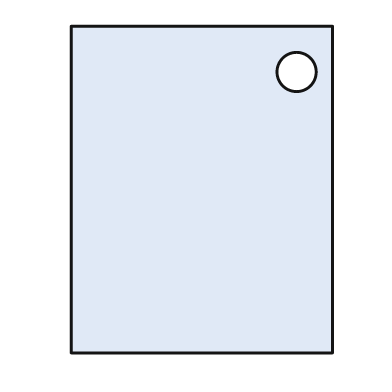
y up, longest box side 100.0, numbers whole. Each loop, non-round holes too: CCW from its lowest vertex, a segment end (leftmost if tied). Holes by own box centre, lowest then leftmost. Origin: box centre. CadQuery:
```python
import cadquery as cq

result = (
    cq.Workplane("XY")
    .moveTo(-40.0, -50.0)
    .lineTo(40.0, -50.0)
    .lineTo(40.0, 50.0)
    .lineTo(-40.0, 50.0)
    .close()
    .moveTo(29.0, 36.0)
    .circle(6.0)
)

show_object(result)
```